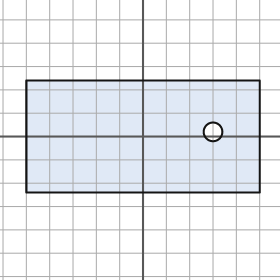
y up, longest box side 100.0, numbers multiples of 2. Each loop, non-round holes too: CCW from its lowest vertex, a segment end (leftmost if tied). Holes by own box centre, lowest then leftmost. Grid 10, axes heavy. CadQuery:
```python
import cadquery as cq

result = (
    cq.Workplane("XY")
    .moveTo(-50.0, -24.0)
    .lineTo(50.0, -24.0)
    .lineTo(50.0, 24.0)
    .lineTo(-50.0, 24.0)
    .close()
    .moveTo(30.0, 2.0)
    .circle(4.0)
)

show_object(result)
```